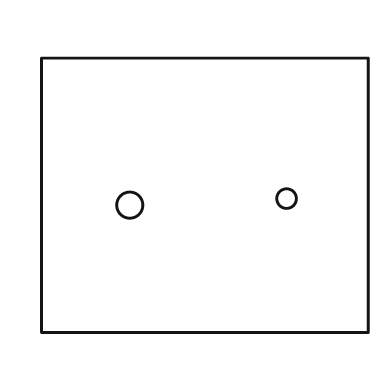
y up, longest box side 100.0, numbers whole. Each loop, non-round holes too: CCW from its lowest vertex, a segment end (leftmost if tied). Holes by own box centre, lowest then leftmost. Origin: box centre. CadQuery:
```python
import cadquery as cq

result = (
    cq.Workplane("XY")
    .moveTo(-50.0, -42.0)
    .lineTo(50.0, -42.0)
    .lineTo(50.0, 42.0)
    .lineTo(-50.0, 42.0)
    .close()
    .moveTo(-23.0, -3.0)
    .circle(4.0)
    .moveTo(25.0, -1.0)
    .circle(3.0)
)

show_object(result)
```